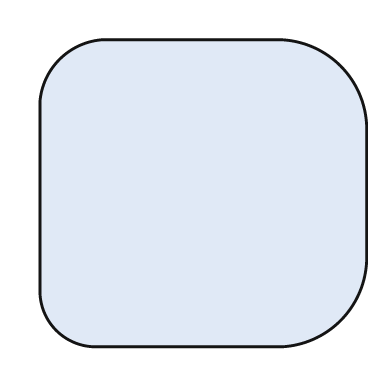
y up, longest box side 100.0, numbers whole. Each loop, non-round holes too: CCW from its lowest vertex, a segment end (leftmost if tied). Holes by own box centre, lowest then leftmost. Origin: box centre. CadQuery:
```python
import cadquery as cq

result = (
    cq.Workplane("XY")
    .moveTo(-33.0, -47.0)
    .lineTo(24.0, -47.0)
    .threePointArc((42.0, -39.0), (50.0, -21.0))
    .lineTo(50.0, 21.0)
    .threePointArc((42.0, 39.0), (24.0, 47.0))
    .lineTo(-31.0, 47.0)
    .threePointArc((-44.0, 41.0), (-50.0, 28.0))
    .lineTo(-50.0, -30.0)
    .threePointArc((-45.0, -42.0), (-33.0, -47.0))
    .close()
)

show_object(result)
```